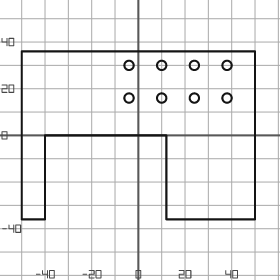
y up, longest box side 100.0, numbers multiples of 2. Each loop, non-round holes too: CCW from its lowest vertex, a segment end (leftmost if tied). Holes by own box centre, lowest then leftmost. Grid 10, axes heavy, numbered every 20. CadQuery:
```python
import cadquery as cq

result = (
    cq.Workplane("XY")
    .moveTo(-50.0, -36.0)
    .lineTo(-40.0, -36.0)
    .lineTo(-40.0, 0.0)
    .lineTo(12.0, 0.0)
    .lineTo(12.0, -36.0)
    .lineTo(50.0, -36.0)
    .lineTo(50.0, 36.0)
    .lineTo(-50.0, 36.0)
    .close()
    .moveTo(-4.0, 16.0)
    .circle(2.0)
    .moveTo(10.0, 16.0)
    .circle(2.0)
    .moveTo(24.0, 16.0)
    .circle(2.0)
    .moveTo(38.0, 16.0)
    .circle(2.0)
    .moveTo(-4.0, 30.0)
    .circle(2.0)
    .moveTo(10.0, 30.0)
    .circle(2.0)
    .moveTo(24.0, 30.0)
    .circle(2.0)
    .moveTo(38.0, 30.0)
    .circle(2.0)
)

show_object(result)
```